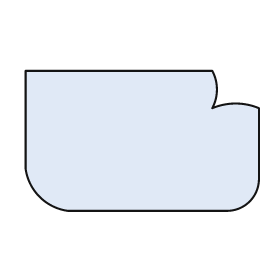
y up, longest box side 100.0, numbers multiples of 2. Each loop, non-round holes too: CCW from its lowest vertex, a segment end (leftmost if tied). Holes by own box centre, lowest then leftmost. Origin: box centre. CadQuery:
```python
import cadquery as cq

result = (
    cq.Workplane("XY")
    .moveTo(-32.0, -30.0)
    .lineTo(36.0, -30.0)
    .threePointArc((46.0, -26.0), (50.0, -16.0))
    .lineTo(50.0, 14.0)
    .threePointArc((40.0, 16.0), (30.0, 14.0))
    .threePointArc((32.0, 22.0), (30.0, 30.0))
    .lineTo(-50.0, 30.0)
    .lineTo(-50.0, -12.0)
    .threePointArc((-44.0, -24.0), (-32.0, -30.0))
    .close()
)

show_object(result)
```